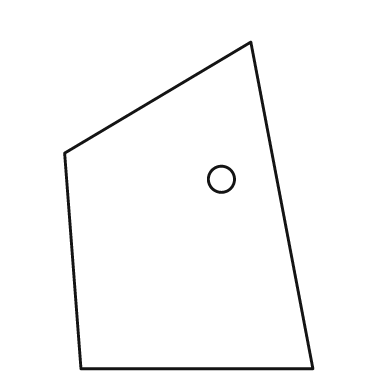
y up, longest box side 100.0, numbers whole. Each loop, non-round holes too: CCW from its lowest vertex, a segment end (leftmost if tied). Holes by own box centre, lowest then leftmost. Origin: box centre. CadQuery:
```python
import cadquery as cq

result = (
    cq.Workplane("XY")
    .moveTo(-33.0, -50.0)
    .lineTo(38.0, -50.0)
    .lineTo(19.0, 50.0)
    .lineTo(-38.0, 16.0)
    .close()
    .moveTo(10.0, 8.0)
    .circle(4.0)
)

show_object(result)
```